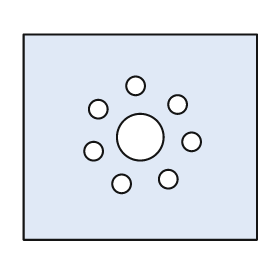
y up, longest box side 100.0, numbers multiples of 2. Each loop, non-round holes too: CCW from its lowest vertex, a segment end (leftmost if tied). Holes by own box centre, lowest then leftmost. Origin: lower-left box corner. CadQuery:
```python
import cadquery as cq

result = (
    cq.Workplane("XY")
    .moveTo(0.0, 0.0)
    .lineTo(100.0, 0.0)
    .lineTo(100.0, 88.0)
    .lineTo(0.0, 88.0)
    .close()
    .moveTo(42.0, 24.0)
    .circle(4.0)
    .moveTo(62.0, 26.0)
    .circle(4.0)
    .moveTo(30.0, 38.0)
    .circle(4.0)
    .moveTo(72.0, 42.0)
    .circle(4.0)
    .moveTo(50.0, 44.0)
    .circle(10.0)
    .moveTo(32.0, 56.0)
    .circle(4.0)
    .moveTo(66.0, 58.0)
    .circle(4.0)
    .moveTo(48.0, 66.0)
    .circle(4.0)
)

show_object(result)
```